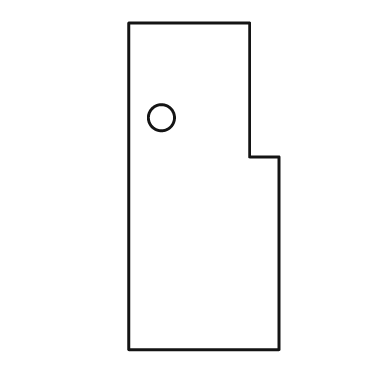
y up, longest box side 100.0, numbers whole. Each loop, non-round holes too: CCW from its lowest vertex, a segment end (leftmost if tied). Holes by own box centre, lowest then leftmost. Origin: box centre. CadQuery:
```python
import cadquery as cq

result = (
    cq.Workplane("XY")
    .moveTo(-23.0, -50.0)
    .lineTo(23.0, -50.0)
    .lineTo(23.0, 9.0)
    .lineTo(14.0, 9.0)
    .lineTo(14.0, 50.0)
    .lineTo(-23.0, 50.0)
    .close()
    .moveTo(-13.0, 21.0)
    .circle(4.0)
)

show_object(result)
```